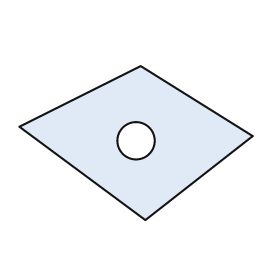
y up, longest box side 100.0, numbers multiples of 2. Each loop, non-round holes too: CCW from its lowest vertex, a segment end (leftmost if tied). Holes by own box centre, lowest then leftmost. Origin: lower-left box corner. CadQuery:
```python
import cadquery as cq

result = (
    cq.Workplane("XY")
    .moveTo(54.0, 0.0)
    .lineTo(100.0, 36.0)
    .lineTo(52.0, 66.0)
    .lineTo(0.0, 40.0)
    .close()
    .moveTo(50.0, 34.0)
    .circle(8.0)
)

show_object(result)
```